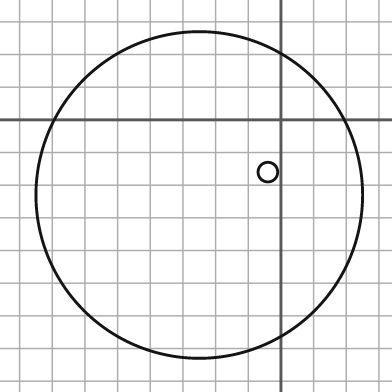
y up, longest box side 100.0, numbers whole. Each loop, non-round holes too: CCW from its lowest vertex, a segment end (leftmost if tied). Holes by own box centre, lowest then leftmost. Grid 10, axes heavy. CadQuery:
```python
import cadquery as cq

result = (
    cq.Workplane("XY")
    .moveTo(-25.0, -23.0)
    .circle(50.0)
    .moveTo(-4.0, -16.0)
    .circle(3.0)
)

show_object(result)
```